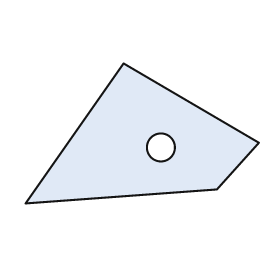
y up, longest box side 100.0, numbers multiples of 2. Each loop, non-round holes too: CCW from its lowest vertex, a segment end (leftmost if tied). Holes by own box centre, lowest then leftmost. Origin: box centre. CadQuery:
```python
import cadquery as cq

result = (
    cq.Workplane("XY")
    .moveTo(-50.0, -30.0)
    .lineTo(32.0, -24.0)
    .lineTo(50.0, -4.0)
    .lineTo(-8.0, 30.0)
    .close()
    .moveTo(8.0, -6.0)
    .circle(6.0)
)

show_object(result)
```